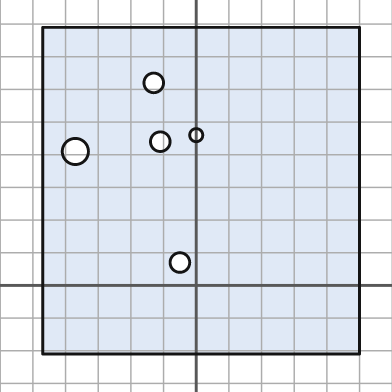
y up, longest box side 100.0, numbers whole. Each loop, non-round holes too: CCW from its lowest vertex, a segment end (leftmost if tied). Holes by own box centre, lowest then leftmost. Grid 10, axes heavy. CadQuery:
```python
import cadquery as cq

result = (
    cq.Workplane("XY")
    .moveTo(-47.0, -21.0)
    .lineTo(50.0, -21.0)
    .lineTo(50.0, 79.0)
    .lineTo(-47.0, 79.0)
    .close()
    .moveTo(-5.0, 7.0)
    .circle(3.0)
    .moveTo(-37.0, 41.0)
    .circle(4.0)
    .moveTo(-11.0, 44.0)
    .circle(3.0)
    .moveTo(0.0, 46.0)
    .circle(2.0)
    .moveTo(-13.0, 62.0)
    .circle(3.0)
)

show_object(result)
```